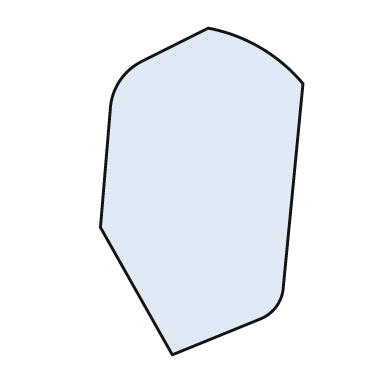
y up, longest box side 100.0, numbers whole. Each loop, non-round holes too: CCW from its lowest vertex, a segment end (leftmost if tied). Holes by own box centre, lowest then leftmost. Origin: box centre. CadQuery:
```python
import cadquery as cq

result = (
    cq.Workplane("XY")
    .moveTo(-9.0, -50.0)
    .lineTo(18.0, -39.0)
    .threePointArc((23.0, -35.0), (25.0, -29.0))
    .lineTo(31.0, 33.0)
    .threePointArc((18.0, 44.0), (2.0, 50.0))
    .lineTo(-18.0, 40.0)
    .threePointArc((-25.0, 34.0), (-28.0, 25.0))
    .lineTo(-31.0, -11.0)
    .close()
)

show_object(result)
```